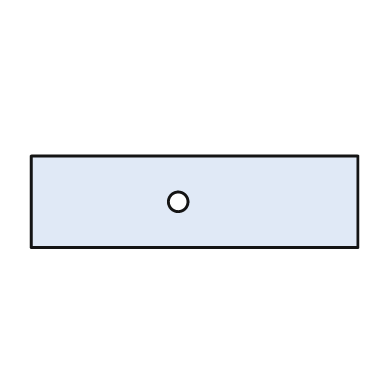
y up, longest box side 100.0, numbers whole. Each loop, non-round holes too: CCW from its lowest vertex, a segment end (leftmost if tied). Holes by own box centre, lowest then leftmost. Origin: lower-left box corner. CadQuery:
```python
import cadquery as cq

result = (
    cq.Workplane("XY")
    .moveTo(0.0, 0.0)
    .lineTo(100.0, 0.0)
    .lineTo(100.0, 28.0)
    .lineTo(0.0, 28.0)
    .close()
    .moveTo(45.0, 14.0)
    .circle(3.0)
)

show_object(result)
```